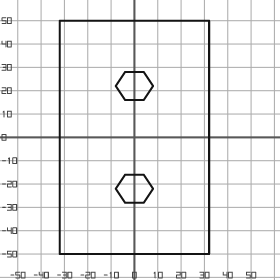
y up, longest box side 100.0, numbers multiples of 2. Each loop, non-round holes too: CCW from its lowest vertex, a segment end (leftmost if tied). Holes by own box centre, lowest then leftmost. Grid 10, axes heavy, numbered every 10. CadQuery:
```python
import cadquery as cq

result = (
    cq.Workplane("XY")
    .moveTo(-32.0, -50.0)
    .lineTo(32.0, -50.0)
    .lineTo(32.0, 50.0)
    .lineTo(-32.0, 50.0)
    .close()
    .moveTo(-4.0, -28.0)
    .lineTo(4.0, -28.0)
    .lineTo(8.0, -22.0)
    .lineTo(4.0, -16.0)
    .lineTo(-4.0, -16.0)
    .lineTo(-8.0, -22.0)
    .close()
    .moveTo(-4.0, 16.0)
    .lineTo(4.0, 16.0)
    .lineTo(8.0, 22.0)
    .lineTo(4.0, 28.0)
    .lineTo(-4.0, 28.0)
    .lineTo(-8.0, 22.0)
    .close()
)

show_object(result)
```